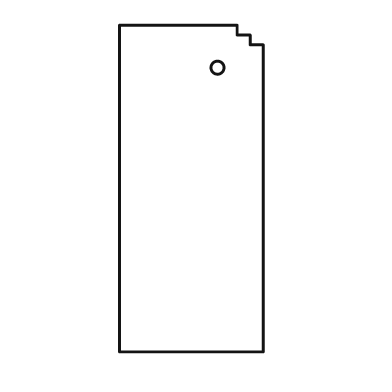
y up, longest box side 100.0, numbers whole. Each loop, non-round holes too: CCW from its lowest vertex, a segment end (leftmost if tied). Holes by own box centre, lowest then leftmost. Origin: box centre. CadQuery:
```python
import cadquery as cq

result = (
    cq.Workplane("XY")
    .moveTo(-22.0, -50.0)
    .lineTo(22.0, -50.0)
    .lineTo(22.0, 44.0)
    .lineTo(18.0, 44.0)
    .lineTo(18.0, 47.0)
    .lineTo(14.0, 47.0)
    .lineTo(14.0, 50.0)
    .lineTo(-22.0, 50.0)
    .close()
    .moveTo(8.0, 37.0)
    .circle(2.0)
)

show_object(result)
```